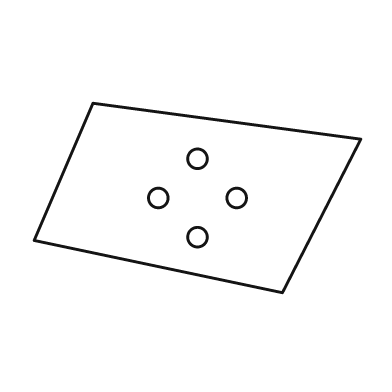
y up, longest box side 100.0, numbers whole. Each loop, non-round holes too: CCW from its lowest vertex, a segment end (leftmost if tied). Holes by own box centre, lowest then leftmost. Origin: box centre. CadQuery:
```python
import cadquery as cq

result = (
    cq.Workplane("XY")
    .moveTo(26.0, -29.0)
    .lineTo(50.0, 18.0)
    .lineTo(-32.0, 29.0)
    .lineTo(-50.0, -13.0)
    .close()
    .moveTo(0.0, -12.0)
    .circle(3.0)
    .moveTo(-12.0, 0.0)
    .circle(3.0)
    .moveTo(12.0, 0.0)
    .circle(3.0)
    .moveTo(0.0, 12.0)
    .circle(3.0)
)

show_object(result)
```